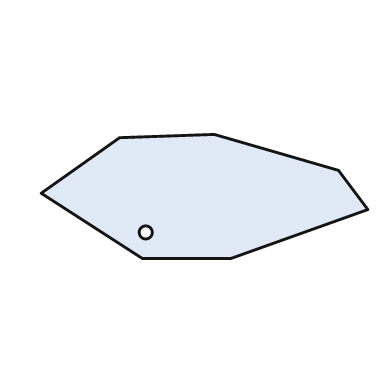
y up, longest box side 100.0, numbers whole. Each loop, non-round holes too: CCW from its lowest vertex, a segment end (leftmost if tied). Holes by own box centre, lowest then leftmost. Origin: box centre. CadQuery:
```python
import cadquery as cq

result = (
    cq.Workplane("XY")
    .moveTo(-19.0, -19.0)
    .lineTo(8.0, -19.0)
    .lineTo(50.0, -4.0)
    .lineTo(41.0, 8.0)
    .lineTo(3.0, 19.0)
    .lineTo(-26.0, 18.0)
    .lineTo(-50.0, 1.0)
    .close()
    .moveTo(-18.0, -11.0)
    .circle(2.0)
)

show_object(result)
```